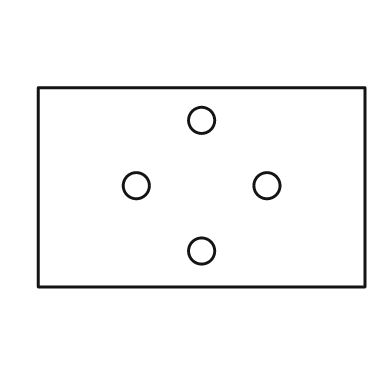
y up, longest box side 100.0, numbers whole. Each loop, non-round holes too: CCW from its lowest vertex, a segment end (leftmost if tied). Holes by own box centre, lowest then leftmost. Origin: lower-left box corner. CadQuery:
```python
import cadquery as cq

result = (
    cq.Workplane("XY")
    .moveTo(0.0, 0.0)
    .lineTo(100.0, 0.0)
    .lineTo(100.0, 61.0)
    .lineTo(0.0, 61.0)
    .close()
    .moveTo(50.0, 11.0)
    .circle(4.0)
    .moveTo(30.0, 31.0)
    .circle(4.0)
    .moveTo(70.0, 31.0)
    .circle(4.0)
    .moveTo(50.0, 51.0)
    .circle(4.0)
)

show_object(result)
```